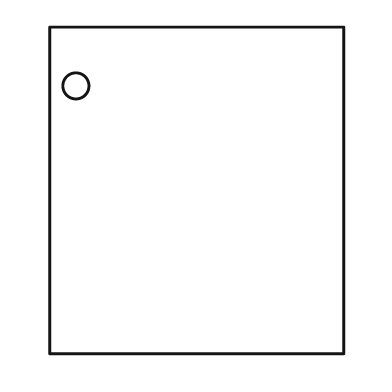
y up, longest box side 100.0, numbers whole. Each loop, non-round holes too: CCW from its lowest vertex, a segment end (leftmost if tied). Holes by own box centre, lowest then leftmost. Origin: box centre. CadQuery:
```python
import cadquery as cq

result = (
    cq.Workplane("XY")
    .moveTo(-45.0, -50.0)
    .lineTo(45.0, -50.0)
    .lineTo(45.0, 50.0)
    .lineTo(-45.0, 50.0)
    .close()
    .moveTo(-37.0, 32.0)
    .circle(4.0)
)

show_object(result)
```